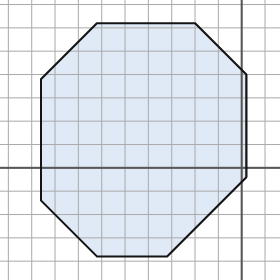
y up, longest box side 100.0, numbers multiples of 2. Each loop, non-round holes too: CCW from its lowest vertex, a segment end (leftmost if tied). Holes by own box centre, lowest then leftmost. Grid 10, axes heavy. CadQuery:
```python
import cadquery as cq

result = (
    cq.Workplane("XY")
    .moveTo(-62.0, -38.0)
    .lineTo(-32.0, -38.0)
    .lineTo(2.0, -4.0)
    .lineTo(2.0, 40.0)
    .lineTo(-20.0, 62.0)
    .lineTo(-62.0, 62.0)
    .lineTo(-86.0, 38.0)
    .lineTo(-86.0, -14.0)
    .close()
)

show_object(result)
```